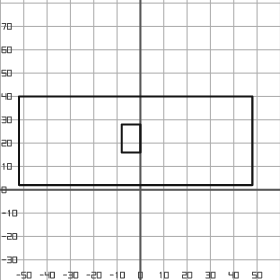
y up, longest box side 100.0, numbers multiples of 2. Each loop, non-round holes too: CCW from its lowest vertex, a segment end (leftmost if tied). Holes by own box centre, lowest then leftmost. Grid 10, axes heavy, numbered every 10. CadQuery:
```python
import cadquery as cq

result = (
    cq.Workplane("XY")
    .moveTo(-52.0, 2.0)
    .lineTo(48.0, 2.0)
    .lineTo(48.0, 40.0)
    .lineTo(-52.0, 40.0)
    .close()
    .moveTo(-8.0, 16.0)
    .lineTo(0.0, 16.0)
    .lineTo(0.0, 28.0)
    .lineTo(-8.0, 28.0)
    .close()
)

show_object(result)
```